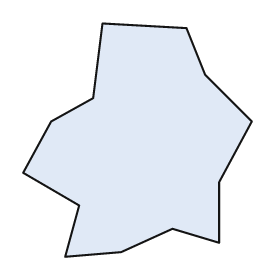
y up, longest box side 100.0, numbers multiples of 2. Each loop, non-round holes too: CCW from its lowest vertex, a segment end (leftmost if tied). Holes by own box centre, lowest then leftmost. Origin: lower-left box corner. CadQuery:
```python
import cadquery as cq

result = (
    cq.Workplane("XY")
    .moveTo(18.0, 0.0)
    .lineTo(42.0, 2.0)
    .lineTo(64.0, 12.0)
    .lineTo(84.0, 6.0)
    .lineTo(84.0, 32.0)
    .lineTo(98.0, 58.0)
    .lineTo(78.0, 78.0)
    .lineTo(70.0, 98.0)
    .lineTo(34.0, 100.0)
    .lineTo(30.0, 68.0)
    .lineTo(12.0, 58.0)
    .lineTo(0.0, 36.0)
    .lineTo(24.0, 22.0)
    .close()
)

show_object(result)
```